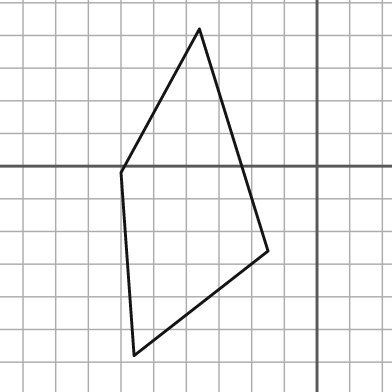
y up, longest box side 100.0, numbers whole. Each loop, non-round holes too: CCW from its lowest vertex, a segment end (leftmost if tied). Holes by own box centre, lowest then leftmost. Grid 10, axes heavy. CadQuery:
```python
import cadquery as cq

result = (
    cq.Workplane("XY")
    .moveTo(-56.0, -58.0)
    .lineTo(-15.0, -26.0)
    .lineTo(-36.0, 42.0)
    .lineTo(-60.0, -2.0)
    .close()
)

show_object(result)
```